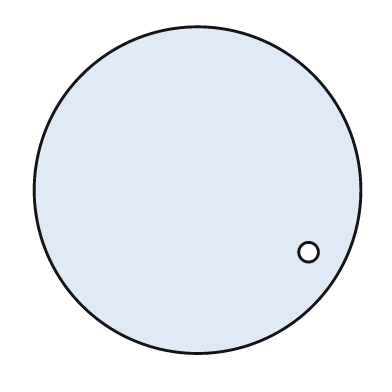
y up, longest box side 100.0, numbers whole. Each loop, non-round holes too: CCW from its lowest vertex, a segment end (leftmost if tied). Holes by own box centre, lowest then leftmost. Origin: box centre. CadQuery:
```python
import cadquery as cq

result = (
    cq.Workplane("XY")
    .moveTo(0.0, 0.0)
    .circle(50.0)
    .moveTo(34.0, -19.0)
    .circle(3.0)
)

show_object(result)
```